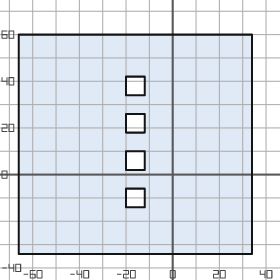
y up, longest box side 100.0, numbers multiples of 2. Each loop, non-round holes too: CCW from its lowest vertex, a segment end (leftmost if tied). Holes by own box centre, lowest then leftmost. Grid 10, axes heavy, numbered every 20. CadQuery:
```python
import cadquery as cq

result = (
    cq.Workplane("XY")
    .moveTo(-66.0, -34.0)
    .lineTo(34.0, -34.0)
    .lineTo(34.0, 60.0)
    .lineTo(-66.0, 60.0)
    .close()
    .moveTo(-20.0, -14.0)
    .lineTo(-12.0, -14.0)
    .lineTo(-12.0, -6.0)
    .lineTo(-20.0, -6.0)
    .close()
    .moveTo(-20.0, 2.0)
    .lineTo(-12.0, 2.0)
    .lineTo(-12.0, 10.0)
    .lineTo(-20.0, 10.0)
    .close()
    .moveTo(-20.0, 18.0)
    .lineTo(-12.0, 18.0)
    .lineTo(-12.0, 26.0)
    .lineTo(-20.0, 26.0)
    .close()
    .moveTo(-20.0, 34.0)
    .lineTo(-12.0, 34.0)
    .lineTo(-12.0, 42.0)
    .lineTo(-20.0, 42.0)
    .close()
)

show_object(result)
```